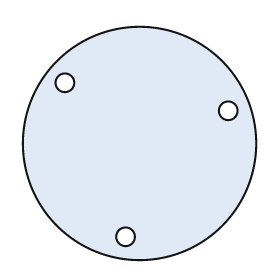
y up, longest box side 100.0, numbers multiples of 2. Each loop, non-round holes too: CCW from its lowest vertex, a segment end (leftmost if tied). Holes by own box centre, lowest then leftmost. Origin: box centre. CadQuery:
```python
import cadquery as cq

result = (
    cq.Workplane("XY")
    .moveTo(0.0, 0.0)
    .circle(50.0)
    .moveTo(-6.0, -40.0)
    .circle(4.0)
    .moveTo(38.0, 14.0)
    .circle(4.0)
    .moveTo(-32.0, 26.0)
    .circle(4.0)
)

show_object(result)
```